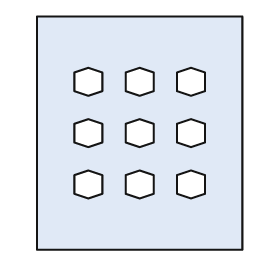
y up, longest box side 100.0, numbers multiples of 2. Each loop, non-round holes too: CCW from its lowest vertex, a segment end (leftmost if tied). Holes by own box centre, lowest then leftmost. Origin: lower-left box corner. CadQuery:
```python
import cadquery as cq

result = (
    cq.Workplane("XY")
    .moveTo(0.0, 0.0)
    .lineTo(88.0, 0.0)
    .lineTo(88.0, 100.0)
    .lineTo(0.0, 100.0)
    .close()
    .moveTo(22.0, 22.0)
    .lineTo(28.0, 24.0)
    .lineTo(28.0, 32.0)
    .lineTo(22.0, 34.0)
    .lineTo(16.0, 32.0)
    .lineTo(16.0, 24.0)
    .close()
    .moveTo(44.0, 22.0)
    .lineTo(50.0, 24.0)
    .lineTo(50.0, 32.0)
    .lineTo(44.0, 34.0)
    .lineTo(38.0, 32.0)
    .lineTo(38.0, 24.0)
    .close()
    .moveTo(66.0, 22.0)
    .lineTo(72.0, 24.0)
    .lineTo(72.0, 32.0)
    .lineTo(66.0, 34.0)
    .lineTo(60.0, 32.0)
    .lineTo(60.0, 24.0)
    .close()
    .moveTo(22.0, 44.0)
    .lineTo(28.0, 46.0)
    .lineTo(28.0, 54.0)
    .lineTo(22.0, 56.0)
    .lineTo(16.0, 54.0)
    .lineTo(16.0, 46.0)
    .close()
    .moveTo(44.0, 44.0)
    .lineTo(50.0, 46.0)
    .lineTo(50.0, 54.0)
    .lineTo(44.0, 56.0)
    .lineTo(38.0, 54.0)
    .lineTo(38.0, 46.0)
    .close()
    .moveTo(66.0, 44.0)
    .lineTo(72.0, 46.0)
    .lineTo(72.0, 54.0)
    .lineTo(66.0, 56.0)
    .lineTo(60.0, 54.0)
    .lineTo(60.0, 46.0)
    .close()
    .moveTo(22.0, 66.0)
    .lineTo(28.0, 68.0)
    .lineTo(28.0, 76.0)
    .lineTo(22.0, 78.0)
    .lineTo(16.0, 76.0)
    .lineTo(16.0, 68.0)
    .close()
    .moveTo(44.0, 66.0)
    .lineTo(50.0, 68.0)
    .lineTo(50.0, 76.0)
    .lineTo(44.0, 78.0)
    .lineTo(38.0, 76.0)
    .lineTo(38.0, 68.0)
    .close()
    .moveTo(66.0, 66.0)
    .lineTo(72.0, 68.0)
    .lineTo(72.0, 76.0)
    .lineTo(66.0, 78.0)
    .lineTo(60.0, 76.0)
    .lineTo(60.0, 68.0)
    .close()
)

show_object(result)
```